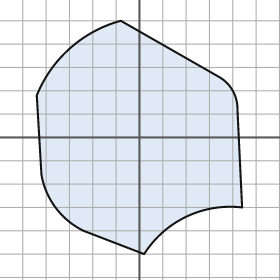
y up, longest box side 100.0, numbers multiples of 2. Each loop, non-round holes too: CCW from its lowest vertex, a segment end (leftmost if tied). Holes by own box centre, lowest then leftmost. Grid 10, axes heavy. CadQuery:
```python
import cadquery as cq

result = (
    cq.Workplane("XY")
    .moveTo(2.0, -50.0)
    .threePointArc((20.0, -34.0), (44.0, -30.0))
    .lineTo(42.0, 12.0)
    .threePointArc((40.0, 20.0), (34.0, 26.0))
    .lineTo(-8.0, 50.0)
    .threePointArc((-30.0, 38.0), (-44.0, 18.0))
    .lineTo(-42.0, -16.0)
    .threePointArc((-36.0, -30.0), (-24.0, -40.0))
    .close()
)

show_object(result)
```